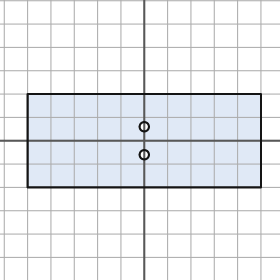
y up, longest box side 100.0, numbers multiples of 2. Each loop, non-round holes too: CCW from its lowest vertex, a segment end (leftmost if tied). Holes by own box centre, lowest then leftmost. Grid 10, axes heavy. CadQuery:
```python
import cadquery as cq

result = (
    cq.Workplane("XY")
    .moveTo(-50.0, -20.0)
    .lineTo(50.0, -20.0)
    .lineTo(50.0, 20.0)
    .lineTo(-50.0, 20.0)
    .close()
    .moveTo(0.0, -6.0)
    .circle(2.0)
    .moveTo(0.0, 6.0)
    .circle(2.0)
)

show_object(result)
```